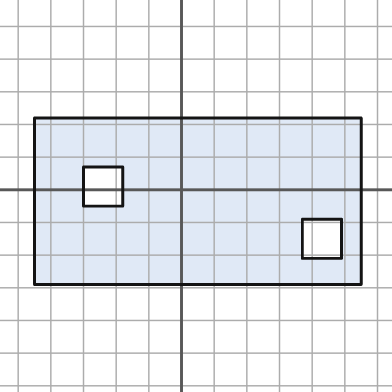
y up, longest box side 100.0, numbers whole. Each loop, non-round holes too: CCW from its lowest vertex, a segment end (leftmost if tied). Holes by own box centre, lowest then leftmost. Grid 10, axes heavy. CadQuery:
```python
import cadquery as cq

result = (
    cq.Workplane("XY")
    .moveTo(-45.0, -29.0)
    .lineTo(55.0, -29.0)
    .lineTo(55.0, 22.0)
    .lineTo(-45.0, 22.0)
    .close()
    .moveTo(37.0, -21.0)
    .lineTo(49.0, -21.0)
    .lineTo(49.0, -9.0)
    .lineTo(37.0, -9.0)
    .close()
    .moveTo(-30.0, -5.0)
    .lineTo(-18.0, -5.0)
    .lineTo(-18.0, 7.0)
    .lineTo(-30.0, 7.0)
    .close()
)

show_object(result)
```